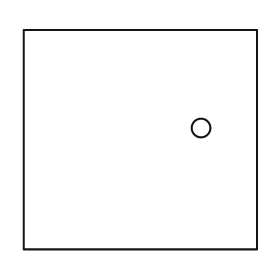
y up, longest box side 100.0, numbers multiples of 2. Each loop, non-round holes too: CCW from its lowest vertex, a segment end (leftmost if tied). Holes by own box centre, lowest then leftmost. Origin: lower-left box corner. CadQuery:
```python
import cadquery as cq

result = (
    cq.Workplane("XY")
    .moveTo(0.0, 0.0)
    .lineTo(100.0, 0.0)
    .lineTo(100.0, 94.0)
    .lineTo(0.0, 94.0)
    .close()
    .moveTo(76.0, 52.0)
    .circle(4.0)
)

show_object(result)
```